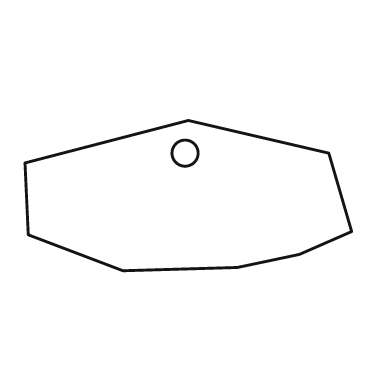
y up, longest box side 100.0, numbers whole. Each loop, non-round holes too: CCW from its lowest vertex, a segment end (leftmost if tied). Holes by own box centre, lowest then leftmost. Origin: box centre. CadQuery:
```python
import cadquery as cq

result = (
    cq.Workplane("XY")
    .moveTo(-20.0, -23.0)
    .lineTo(15.0, -22.0)
    .lineTo(34.0, -18.0)
    .lineTo(50.0, -11.0)
    .lineTo(43.0, 13.0)
    .lineTo(0.0, 23.0)
    .lineTo(-50.0, 10.0)
    .lineTo(-49.0, -12.0)
    .close()
    .moveTo(-1.0, 13.0)
    .circle(4.0)
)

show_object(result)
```